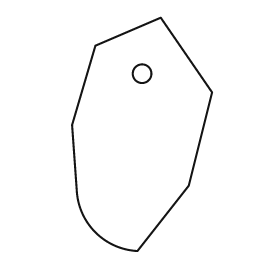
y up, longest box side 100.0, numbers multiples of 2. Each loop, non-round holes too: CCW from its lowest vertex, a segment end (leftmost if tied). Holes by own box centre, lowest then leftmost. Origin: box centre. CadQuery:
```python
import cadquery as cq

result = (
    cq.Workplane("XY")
    .moveTo(-2.0, -50.0)
    .lineTo(20.0, -22.0)
    .lineTo(30.0, 18.0)
    .lineTo(8.0, 50.0)
    .lineTo(-20.0, 38.0)
    .lineTo(-30.0, 4.0)
    .lineTo(-28.0, -24.0)
    .threePointArc((-20.0, -42.0), (-2.0, -50.0))
    .close()
    .moveTo(0.0, 26.0)
    .circle(4.0)
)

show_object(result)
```